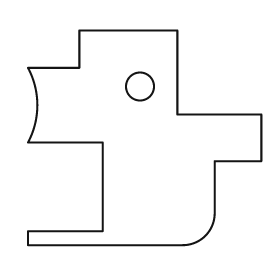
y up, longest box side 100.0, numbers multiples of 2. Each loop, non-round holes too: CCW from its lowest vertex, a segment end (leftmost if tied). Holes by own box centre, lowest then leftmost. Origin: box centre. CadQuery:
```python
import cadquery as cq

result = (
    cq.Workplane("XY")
    .moveTo(-50.0, -46.0)
    .lineTo(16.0, -46.0)
    .threePointArc((26.0, -42.0), (30.0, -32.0))
    .lineTo(30.0, -10.0)
    .lineTo(50.0, -10.0)
    .lineTo(50.0, 10.0)
    .lineTo(14.0, 10.0)
    .lineTo(14.0, 46.0)
    .lineTo(-28.0, 46.0)
    .lineTo(-28.0, 30.0)
    .lineTo(-50.0, 30.0)
    .threePointArc((-46.0, 14.0), (-50.0, -2.0))
    .lineTo(-18.0, -2.0)
    .lineTo(-18.0, -40.0)
    .lineTo(-50.0, -40.0)
    .close()
    .moveTo(-2.0, 22.0)
    .circle(6.0)
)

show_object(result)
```